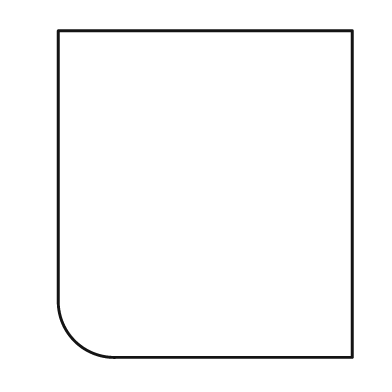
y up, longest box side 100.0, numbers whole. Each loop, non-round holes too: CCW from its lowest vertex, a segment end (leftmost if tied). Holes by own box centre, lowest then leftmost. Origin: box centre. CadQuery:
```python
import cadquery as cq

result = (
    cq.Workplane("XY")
    .moveTo(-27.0, -50.0)
    .lineTo(45.0, -50.0)
    .lineTo(45.0, 50.0)
    .lineTo(-45.0, 50.0)
    .lineTo(-45.0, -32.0)
    .threePointArc((-40.0, -45.0), (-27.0, -50.0))
    .close()
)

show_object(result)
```